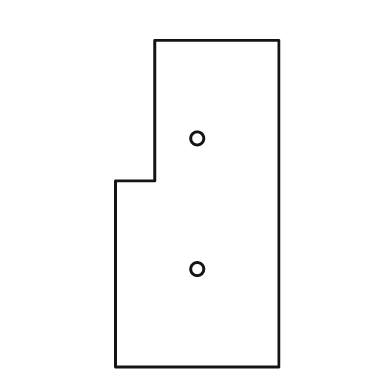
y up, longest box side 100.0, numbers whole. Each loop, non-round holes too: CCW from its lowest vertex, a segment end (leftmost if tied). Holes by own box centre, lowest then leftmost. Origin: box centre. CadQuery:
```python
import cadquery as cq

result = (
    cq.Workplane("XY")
    .moveTo(-25.0, -50.0)
    .lineTo(25.0, -50.0)
    .lineTo(25.0, 50.0)
    .lineTo(-13.0, 50.0)
    .lineTo(-13.0, 7.0)
    .lineTo(-25.0, 7.0)
    .close()
    .moveTo(0.0, -20.0)
    .circle(2.0)
    .moveTo(0.0, 20.0)
    .circle(2.0)
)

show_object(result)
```